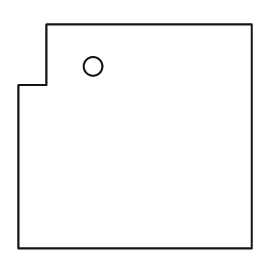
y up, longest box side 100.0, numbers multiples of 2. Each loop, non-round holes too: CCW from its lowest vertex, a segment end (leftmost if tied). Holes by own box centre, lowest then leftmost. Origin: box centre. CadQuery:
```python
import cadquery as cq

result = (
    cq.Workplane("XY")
    .moveTo(-50.0, -48.0)
    .lineTo(50.0, -48.0)
    .lineTo(50.0, 48.0)
    .lineTo(-38.0, 48.0)
    .lineTo(-38.0, 22.0)
    .lineTo(-50.0, 22.0)
    .close()
    .moveTo(-18.0, 30.0)
    .circle(4.0)
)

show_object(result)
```